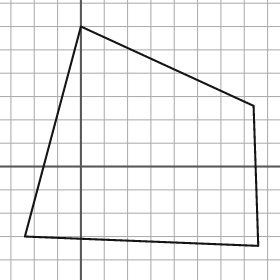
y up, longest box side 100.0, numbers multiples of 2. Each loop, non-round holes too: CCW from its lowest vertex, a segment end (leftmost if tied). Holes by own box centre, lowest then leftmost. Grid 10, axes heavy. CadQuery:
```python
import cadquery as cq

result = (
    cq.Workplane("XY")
    .moveTo(76.0, -34.0)
    .lineTo(74.0, 26.0)
    .lineTo(0.0, 60.0)
    .lineTo(-24.0, -30.0)
    .close()
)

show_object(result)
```